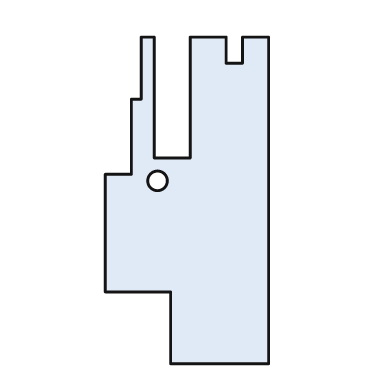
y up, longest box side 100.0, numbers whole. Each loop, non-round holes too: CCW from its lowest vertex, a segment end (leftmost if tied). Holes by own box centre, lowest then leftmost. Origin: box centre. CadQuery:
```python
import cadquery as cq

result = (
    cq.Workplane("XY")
    .moveTo(-5.0, -50.0)
    .lineTo(25.0, -50.0)
    .lineTo(25.0, 50.0)
    .lineTo(17.0, 50.0)
    .lineTo(17.0, 42.0)
    .lineTo(12.0, 42.0)
    .lineTo(12.0, 50.0)
    .lineTo(1.0, 50.0)
    .lineTo(1.0, 13.0)
    .lineTo(-10.0, 13.0)
    .lineTo(-10.0, 50.0)
    .lineTo(-14.0, 50.0)
    .lineTo(-14.0, 31.0)
    .lineTo(-17.0, 31.0)
    .lineTo(-17.0, 8.0)
    .lineTo(-25.0, 8.0)
    .lineTo(-25.0, -28.0)
    .lineTo(-5.0, -28.0)
    .close()
    .moveTo(-9.0, 6.0)
    .circle(3.0)
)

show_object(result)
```